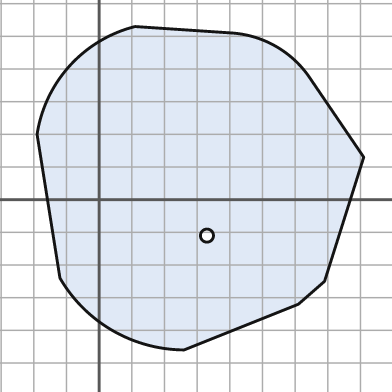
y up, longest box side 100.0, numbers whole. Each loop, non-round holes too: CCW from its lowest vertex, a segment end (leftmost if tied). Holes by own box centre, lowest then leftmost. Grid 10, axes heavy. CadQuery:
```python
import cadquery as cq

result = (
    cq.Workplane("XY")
    .moveTo(26.0, -46.0)
    .lineTo(61.0, -32.0)
    .lineTo(69.0, -25.0)
    .lineTo(81.0, 13.0)
    .lineTo(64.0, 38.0)
    .threePointArc((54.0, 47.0), (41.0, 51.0))
    .lineTo(11.0, 53.0)
    .threePointArc((-9.0, 41.0), (-19.0, 20.0))
    .lineTo(-12.0, -24.0)
    .threePointArc((4.0, -40.0), (26.0, -46.0))
    .close()
    .moveTo(33.0, -11.0)
    .circle(2.0)
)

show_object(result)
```